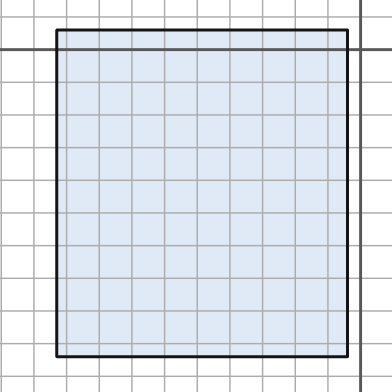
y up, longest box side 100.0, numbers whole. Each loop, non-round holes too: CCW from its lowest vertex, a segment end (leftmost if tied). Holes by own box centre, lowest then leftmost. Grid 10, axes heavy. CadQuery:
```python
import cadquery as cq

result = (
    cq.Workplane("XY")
    .moveTo(-93.0, -94.0)
    .lineTo(-4.0, -94.0)
    .lineTo(-4.0, 6.0)
    .lineTo(-93.0, 6.0)
    .close()
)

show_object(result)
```